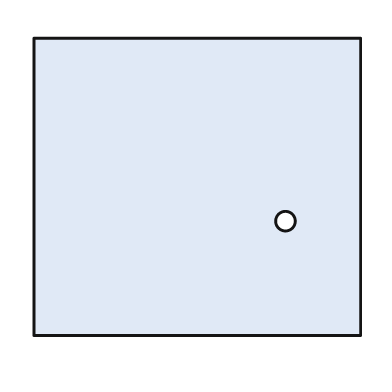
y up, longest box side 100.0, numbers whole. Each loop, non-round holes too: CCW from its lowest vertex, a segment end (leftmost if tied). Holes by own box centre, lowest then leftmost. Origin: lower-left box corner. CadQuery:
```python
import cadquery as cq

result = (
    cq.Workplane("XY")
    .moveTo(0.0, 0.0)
    .lineTo(100.0, 0.0)
    .lineTo(100.0, 91.0)
    .lineTo(0.0, 91.0)
    .close()
    .moveTo(77.0, 35.0)
    .circle(3.0)
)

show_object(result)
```